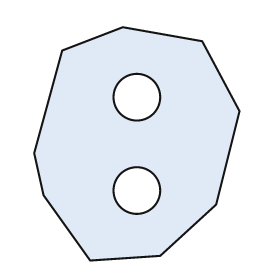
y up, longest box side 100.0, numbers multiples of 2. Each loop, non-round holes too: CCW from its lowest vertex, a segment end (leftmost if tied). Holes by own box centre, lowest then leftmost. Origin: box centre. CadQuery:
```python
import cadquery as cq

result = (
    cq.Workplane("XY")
    .moveTo(-20.0, -50.0)
    .lineTo(10.0, -48.0)
    .lineTo(34.0, -26.0)
    .lineTo(44.0, 14.0)
    .lineTo(28.0, 44.0)
    .lineTo(-6.0, 50.0)
    .lineTo(-32.0, 40.0)
    .lineTo(-44.0, -4.0)
    .lineTo(-40.0, -22.0)
    .close()
    .moveTo(0.0, -20.0)
    .circle(10.0)
    .moveTo(0.0, 20.0)
    .circle(10.0)
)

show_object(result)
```